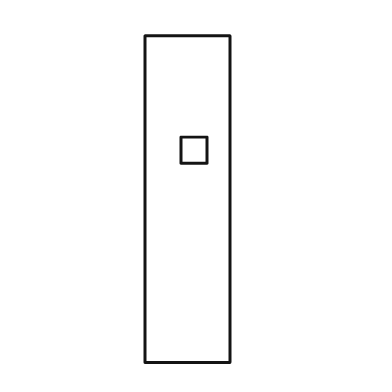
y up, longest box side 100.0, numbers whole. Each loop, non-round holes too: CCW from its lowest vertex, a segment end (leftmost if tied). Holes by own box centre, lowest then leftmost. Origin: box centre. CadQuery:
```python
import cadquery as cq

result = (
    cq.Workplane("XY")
    .moveTo(-13.0, -50.0)
    .lineTo(13.0, -50.0)
    .lineTo(13.0, 50.0)
    .lineTo(-13.0, 50.0)
    .close()
    .moveTo(-2.0, 11.0)
    .lineTo(6.0, 11.0)
    .lineTo(6.0, 19.0)
    .lineTo(-2.0, 19.0)
    .close()
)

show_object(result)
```